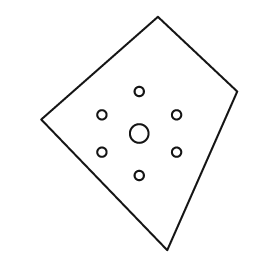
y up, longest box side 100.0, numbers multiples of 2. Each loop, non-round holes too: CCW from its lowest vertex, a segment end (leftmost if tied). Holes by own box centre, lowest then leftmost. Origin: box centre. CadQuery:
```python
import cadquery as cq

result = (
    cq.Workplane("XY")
    .moveTo(12.0, -50.0)
    .lineTo(42.0, 18.0)
    .lineTo(8.0, 50.0)
    .lineTo(-42.0, 6.0)
    .close()
    .moveTo(0.0, -18.0)
    .circle(2.0)
    .moveTo(-16.0, -8.0)
    .circle(2.0)
    .moveTo(16.0, -8.0)
    .circle(2.0)
    .moveTo(0.0, 0.0)
    .circle(4.0)
    .moveTo(-16.0, 8.0)
    .circle(2.0)
    .moveTo(16.0, 8.0)
    .circle(2.0)
    .moveTo(0.0, 18.0)
    .circle(2.0)
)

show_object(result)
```